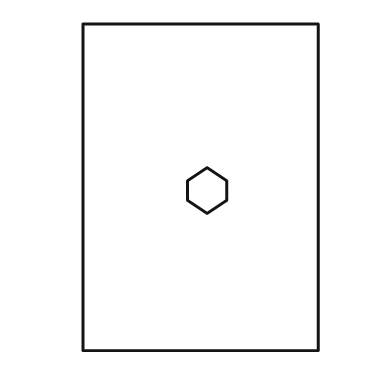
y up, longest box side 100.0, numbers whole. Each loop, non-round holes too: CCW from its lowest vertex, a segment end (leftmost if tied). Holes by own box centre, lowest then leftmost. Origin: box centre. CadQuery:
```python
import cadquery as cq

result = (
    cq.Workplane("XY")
    .moveTo(-36.0, -50.0)
    .lineTo(36.0, -50.0)
    .lineTo(36.0, 50.0)
    .lineTo(-36.0, 50.0)
    .close()
    .moveTo(2.0, -8.0)
    .lineTo(8.0, -4.0)
    .lineTo(8.0, 2.0)
    .lineTo(2.0, 6.0)
    .lineTo(-4.0, 2.0)
    .lineTo(-4.0, -4.0)
    .close()
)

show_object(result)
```